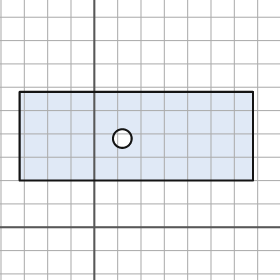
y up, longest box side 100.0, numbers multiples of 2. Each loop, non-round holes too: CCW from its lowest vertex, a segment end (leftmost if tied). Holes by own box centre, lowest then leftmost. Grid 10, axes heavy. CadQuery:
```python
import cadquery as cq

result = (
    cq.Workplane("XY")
    .moveTo(-32.0, 20.0)
    .lineTo(68.0, 20.0)
    .lineTo(68.0, 58.0)
    .lineTo(-32.0, 58.0)
    .close()
    .moveTo(12.0, 38.0)
    .circle(4.0)
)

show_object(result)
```